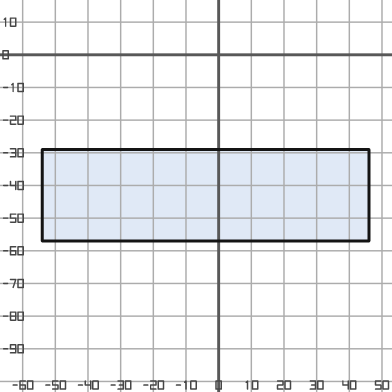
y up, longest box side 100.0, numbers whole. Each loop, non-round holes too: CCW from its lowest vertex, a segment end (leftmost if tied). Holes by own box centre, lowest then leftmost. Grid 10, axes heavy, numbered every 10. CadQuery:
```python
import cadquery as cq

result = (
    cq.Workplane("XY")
    .moveTo(-54.0, -57.0)
    .lineTo(46.0, -57.0)
    .lineTo(46.0, -29.0)
    .lineTo(-54.0, -29.0)
    .close()
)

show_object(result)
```